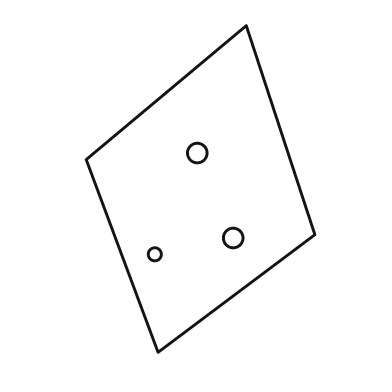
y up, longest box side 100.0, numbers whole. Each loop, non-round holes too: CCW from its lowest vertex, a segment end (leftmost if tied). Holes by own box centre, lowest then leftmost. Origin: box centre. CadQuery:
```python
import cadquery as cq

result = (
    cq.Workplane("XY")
    .moveTo(-13.0, -50.0)
    .lineTo(35.0, -14.0)
    .lineTo(14.0, 50.0)
    .lineTo(-35.0, 9.0)
    .close()
    .moveTo(-14.0, -20.0)
    .circle(2.0)
    .moveTo(10.0, -15.0)
    .circle(3.0)
    .moveTo(-1.0, 11.0)
    .circle(3.0)
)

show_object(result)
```